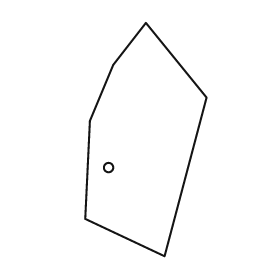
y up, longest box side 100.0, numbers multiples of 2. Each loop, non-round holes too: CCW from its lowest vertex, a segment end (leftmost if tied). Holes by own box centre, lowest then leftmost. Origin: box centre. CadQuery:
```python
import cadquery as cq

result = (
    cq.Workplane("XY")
    .moveTo(8.0, -50.0)
    .lineTo(26.0, 18.0)
    .lineTo(0.0, 50.0)
    .lineTo(-14.0, 32.0)
    .lineTo(-24.0, 8.0)
    .lineTo(-26.0, -34.0)
    .close()
    .moveTo(-16.0, -12.0)
    .circle(2.0)
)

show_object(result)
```